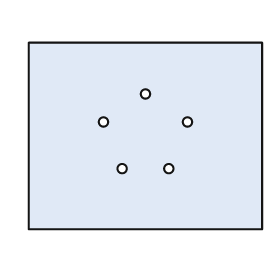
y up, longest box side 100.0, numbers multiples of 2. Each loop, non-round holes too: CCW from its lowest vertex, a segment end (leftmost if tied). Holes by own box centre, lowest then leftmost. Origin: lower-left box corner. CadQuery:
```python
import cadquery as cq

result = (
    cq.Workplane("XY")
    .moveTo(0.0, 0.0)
    .lineTo(100.0, 0.0)
    .lineTo(100.0, 80.0)
    .lineTo(0.0, 80.0)
    .close()
    .moveTo(40.0, 26.0)
    .circle(2.0)
    .moveTo(60.0, 26.0)
    .circle(2.0)
    .moveTo(32.0, 46.0)
    .circle(2.0)
    .moveTo(68.0, 46.0)
    .circle(2.0)
    .moveTo(50.0, 58.0)
    .circle(2.0)
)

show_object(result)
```